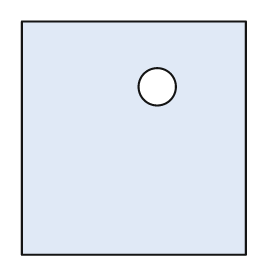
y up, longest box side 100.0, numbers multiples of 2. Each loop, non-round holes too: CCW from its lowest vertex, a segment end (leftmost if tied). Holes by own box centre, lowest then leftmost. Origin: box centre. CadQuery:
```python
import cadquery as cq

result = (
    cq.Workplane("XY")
    .moveTo(-48.0, -50.0)
    .lineTo(48.0, -50.0)
    .lineTo(48.0, 50.0)
    .lineTo(-48.0, 50.0)
    .close()
    .moveTo(10.0, 22.0)
    .circle(8.0)
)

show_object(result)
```